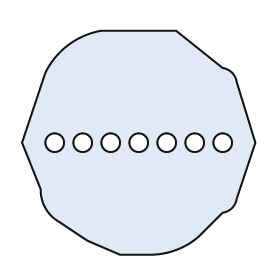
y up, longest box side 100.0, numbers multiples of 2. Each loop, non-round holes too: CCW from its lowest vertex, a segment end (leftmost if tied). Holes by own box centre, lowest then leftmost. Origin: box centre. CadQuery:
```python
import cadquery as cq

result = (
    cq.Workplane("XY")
    .moveTo(-8.0, -48.0)
    .lineTo(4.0, -48.0)
    .threePointArc((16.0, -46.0), (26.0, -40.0))
    .lineTo(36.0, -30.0)
    .threePointArc((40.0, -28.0), (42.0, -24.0))
    .lineTo(50.0, 0.0)
    .lineTo(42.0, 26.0)
    .threePointArc((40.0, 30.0), (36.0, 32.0))
    .lineTo(16.0, 48.0)
    .lineTo(-16.0, 48.0)
    .threePointArc((-30.0, 42.0), (-40.0, 30.0))
    .lineTo(-50.0, 0.0)
    .lineTo(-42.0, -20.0)
    .threePointArc((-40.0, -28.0), (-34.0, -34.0))
    .lineTo(-22.0, -42.0)
    .close()
    .moveTo(-36.0, 0.0)
    .circle(4.0)
    .moveTo(-24.0, 0.0)
    .circle(4.0)
    .moveTo(-12.0, 0.0)
    .circle(4.0)
    .moveTo(0.0, 0.0)
    .circle(4.0)
    .moveTo(12.0, 0.0)
    .circle(4.0)
    .moveTo(24.0, 0.0)
    .circle(4.0)
    .moveTo(36.0, 0.0)
    .circle(4.0)
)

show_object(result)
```